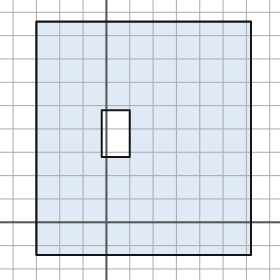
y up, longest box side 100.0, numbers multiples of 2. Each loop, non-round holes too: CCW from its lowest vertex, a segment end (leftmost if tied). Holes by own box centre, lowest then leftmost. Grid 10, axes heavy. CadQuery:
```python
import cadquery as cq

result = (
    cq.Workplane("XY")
    .moveTo(-30.0, -14.0)
    .lineTo(62.0, -14.0)
    .lineTo(62.0, 86.0)
    .lineTo(-30.0, 86.0)
    .close()
    .moveTo(-2.0, 28.0)
    .lineTo(10.0, 28.0)
    .lineTo(10.0, 48.0)
    .lineTo(-2.0, 48.0)
    .close()
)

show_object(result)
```